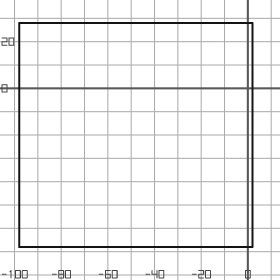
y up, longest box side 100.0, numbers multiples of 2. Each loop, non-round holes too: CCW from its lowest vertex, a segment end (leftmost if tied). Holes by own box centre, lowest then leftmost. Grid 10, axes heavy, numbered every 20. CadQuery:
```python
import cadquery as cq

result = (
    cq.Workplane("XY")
    .moveTo(-98.0, -68.0)
    .lineTo(2.0, -68.0)
    .lineTo(2.0, 28.0)
    .lineTo(-98.0, 28.0)
    .close()
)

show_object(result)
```